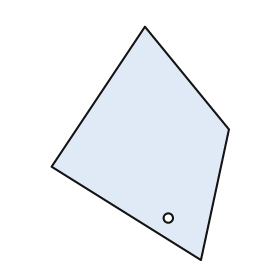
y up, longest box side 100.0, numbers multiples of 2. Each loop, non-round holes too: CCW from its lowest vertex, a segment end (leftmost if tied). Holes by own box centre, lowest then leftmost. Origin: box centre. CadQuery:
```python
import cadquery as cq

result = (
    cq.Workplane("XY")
    .moveTo(26.0, -50.0)
    .lineTo(38.0, 6.0)
    .lineTo(2.0, 50.0)
    .lineTo(-38.0, -10.0)
    .close()
    .moveTo(12.0, -32.0)
    .circle(2.0)
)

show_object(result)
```